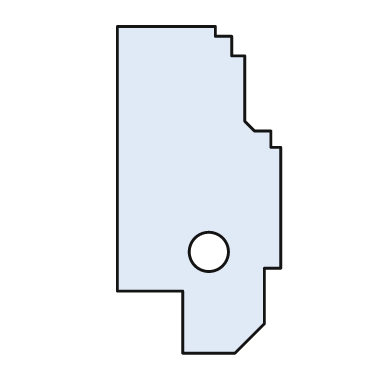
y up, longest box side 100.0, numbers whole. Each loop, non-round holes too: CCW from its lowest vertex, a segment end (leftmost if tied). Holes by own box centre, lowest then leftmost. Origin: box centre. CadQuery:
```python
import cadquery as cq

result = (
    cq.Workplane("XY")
    .moveTo(-5.0, -50.0)
    .lineTo(11.0, -50.0)
    .lineTo(20.0, -41.0)
    .lineTo(20.0, -24.0)
    .lineTo(25.0, -24.0)
    .lineTo(25.0, 13.0)
    .lineTo(22.0, 13.0)
    .lineTo(22.0, 18.0)
    .lineTo(17.0, 18.0)
    .lineTo(14.0, 21.0)
    .lineTo(14.0, 41.0)
    .lineTo(10.0, 41.0)
    .lineTo(10.0, 47.0)
    .lineTo(5.0, 47.0)
    .lineTo(5.0, 50.0)
    .lineTo(-25.0, 50.0)
    .lineTo(-25.0, -31.0)
    .lineTo(-5.0, -31.0)
    .close()
    .moveTo(3.0, -19.0)
    .circle(6.0)
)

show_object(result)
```